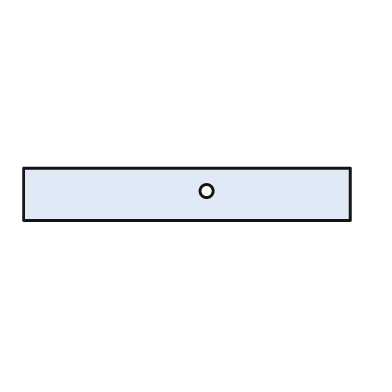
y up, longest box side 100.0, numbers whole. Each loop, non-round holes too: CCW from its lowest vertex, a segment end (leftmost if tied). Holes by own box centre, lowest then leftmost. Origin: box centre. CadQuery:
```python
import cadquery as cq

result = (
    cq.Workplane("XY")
    .moveTo(-50.0, -8.0)
    .lineTo(50.0, -8.0)
    .lineTo(50.0, 8.0)
    .lineTo(-50.0, 8.0)
    .close()
    .moveTo(6.0, 1.0)
    .circle(2.0)
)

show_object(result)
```